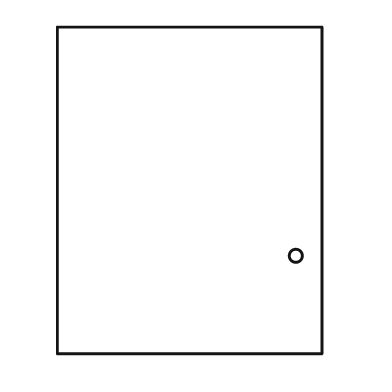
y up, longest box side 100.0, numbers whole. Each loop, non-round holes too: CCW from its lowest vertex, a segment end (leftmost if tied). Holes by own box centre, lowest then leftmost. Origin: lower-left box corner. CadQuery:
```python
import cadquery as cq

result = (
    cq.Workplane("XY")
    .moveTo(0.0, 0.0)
    .lineTo(81.0, 0.0)
    .lineTo(81.0, 100.0)
    .lineTo(0.0, 100.0)
    .close()
    .moveTo(73.0, 30.0)
    .circle(2.0)
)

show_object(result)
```